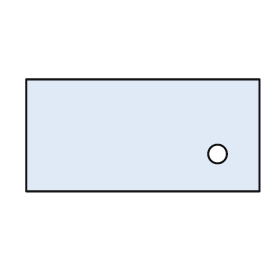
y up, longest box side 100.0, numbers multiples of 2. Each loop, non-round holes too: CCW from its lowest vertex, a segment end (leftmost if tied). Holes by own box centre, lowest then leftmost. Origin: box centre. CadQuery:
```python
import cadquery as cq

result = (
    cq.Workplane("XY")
    .moveTo(-50.0, -24.0)
    .lineTo(50.0, -24.0)
    .lineTo(50.0, 24.0)
    .lineTo(-50.0, 24.0)
    .close()
    .moveTo(32.0, -8.0)
    .circle(4.0)
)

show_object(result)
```